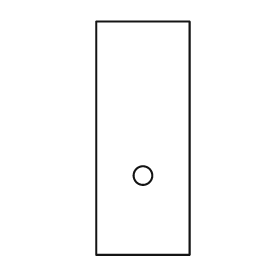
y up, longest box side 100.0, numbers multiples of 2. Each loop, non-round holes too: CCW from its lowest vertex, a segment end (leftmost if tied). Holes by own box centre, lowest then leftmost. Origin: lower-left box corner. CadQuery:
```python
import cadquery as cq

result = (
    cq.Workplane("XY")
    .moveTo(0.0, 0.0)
    .lineTo(40.0, 0.0)
    .lineTo(40.0, 100.0)
    .lineTo(0.0, 100.0)
    .close()
    .moveTo(20.0, 34.0)
    .circle(4.0)
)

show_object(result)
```